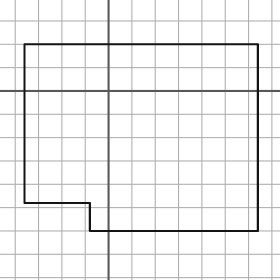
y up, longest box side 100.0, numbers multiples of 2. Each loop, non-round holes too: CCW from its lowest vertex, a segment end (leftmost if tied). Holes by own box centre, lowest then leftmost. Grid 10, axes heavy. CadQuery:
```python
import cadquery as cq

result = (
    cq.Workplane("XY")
    .moveTo(-8.0, -60.0)
    .lineTo(64.0, -60.0)
    .lineTo(64.0, 20.0)
    .lineTo(-36.0, 20.0)
    .lineTo(-36.0, -48.0)
    .lineTo(-8.0, -48.0)
    .close()
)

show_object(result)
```